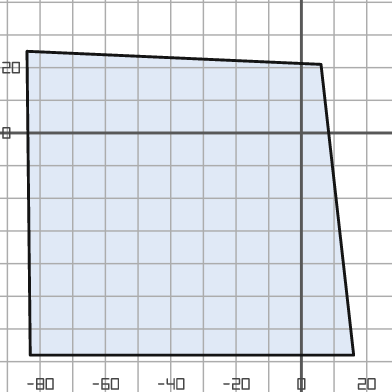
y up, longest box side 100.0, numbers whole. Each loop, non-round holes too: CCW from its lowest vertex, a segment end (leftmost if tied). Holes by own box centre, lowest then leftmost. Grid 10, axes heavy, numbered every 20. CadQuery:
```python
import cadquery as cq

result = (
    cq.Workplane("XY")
    .moveTo(-83.0, -68.0)
    .lineTo(16.0, -68.0)
    .lineTo(6.0, 21.0)
    .lineTo(-84.0, 25.0)
    .close()
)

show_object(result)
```